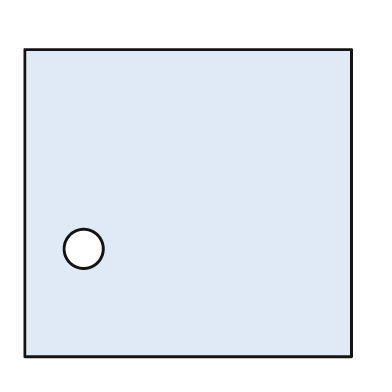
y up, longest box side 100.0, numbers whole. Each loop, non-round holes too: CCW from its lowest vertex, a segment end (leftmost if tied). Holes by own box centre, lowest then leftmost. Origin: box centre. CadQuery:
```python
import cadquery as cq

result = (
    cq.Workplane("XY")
    .moveTo(-50.0, -47.0)
    .lineTo(50.0, -47.0)
    .lineTo(50.0, 47.0)
    .lineTo(-50.0, 47.0)
    .close()
    .moveTo(-32.0, -14.0)
    .circle(6.0)
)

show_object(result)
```